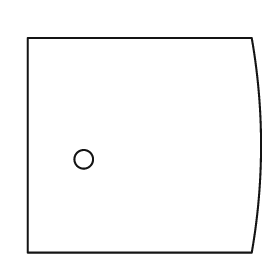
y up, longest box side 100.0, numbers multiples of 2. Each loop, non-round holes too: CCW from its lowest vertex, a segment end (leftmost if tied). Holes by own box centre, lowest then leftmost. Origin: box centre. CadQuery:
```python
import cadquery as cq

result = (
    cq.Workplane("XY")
    .moveTo(-50.0, -46.0)
    .lineTo(46.0, -46.0)
    .threePointArc((50.0, 0.0), (46.0, 46.0))
    .lineTo(-50.0, 46.0)
    .close()
    .moveTo(-26.0, -6.0)
    .circle(4.0)
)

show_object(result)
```